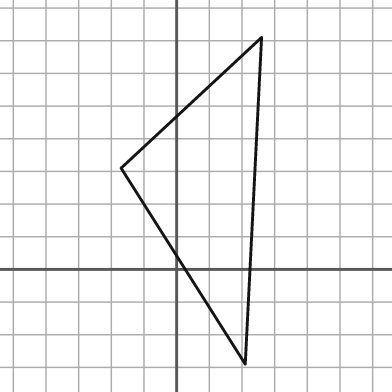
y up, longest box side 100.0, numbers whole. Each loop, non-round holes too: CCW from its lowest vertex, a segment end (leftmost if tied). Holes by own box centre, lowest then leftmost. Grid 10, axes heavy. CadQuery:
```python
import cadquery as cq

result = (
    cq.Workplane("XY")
    .moveTo(21.0, -29.0)
    .lineTo(26.0, 71.0)
    .lineTo(-17.0, 31.0)
    .close()
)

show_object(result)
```